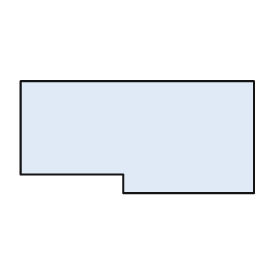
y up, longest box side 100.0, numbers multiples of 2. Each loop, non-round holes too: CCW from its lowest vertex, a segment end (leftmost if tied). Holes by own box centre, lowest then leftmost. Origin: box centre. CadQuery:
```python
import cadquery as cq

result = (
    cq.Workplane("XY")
    .moveTo(-6.0, -24.0)
    .lineTo(50.0, -24.0)
    .lineTo(50.0, 24.0)
    .lineTo(-50.0, 24.0)
    .lineTo(-50.0, -16.0)
    .lineTo(-6.0, -16.0)
    .close()
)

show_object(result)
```